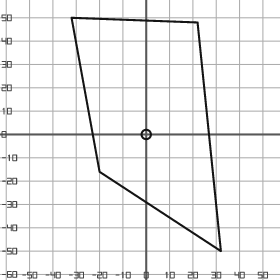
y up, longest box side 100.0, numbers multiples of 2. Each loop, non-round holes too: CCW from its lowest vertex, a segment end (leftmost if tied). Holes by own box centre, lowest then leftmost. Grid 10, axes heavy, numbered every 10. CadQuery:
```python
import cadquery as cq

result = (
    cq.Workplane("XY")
    .moveTo(32.0, -50.0)
    .lineTo(22.0, 48.0)
    .lineTo(-32.0, 50.0)
    .lineTo(-20.0, -16.0)
    .close()
    .moveTo(0.0, 0.0)
    .circle(2.0)
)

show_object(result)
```